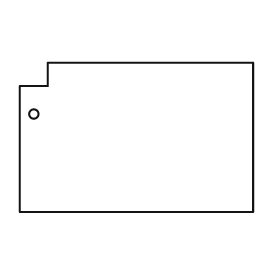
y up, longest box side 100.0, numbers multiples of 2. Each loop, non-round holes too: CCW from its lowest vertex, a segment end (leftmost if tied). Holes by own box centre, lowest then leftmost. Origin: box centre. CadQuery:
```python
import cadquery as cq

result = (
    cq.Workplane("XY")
    .moveTo(-50.0, -32.0)
    .lineTo(50.0, -32.0)
    .lineTo(50.0, 32.0)
    .lineTo(-38.0, 32.0)
    .lineTo(-38.0, 22.0)
    .lineTo(-50.0, 22.0)
    .close()
    .moveTo(-44.0, 10.0)
    .circle(2.0)
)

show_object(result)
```